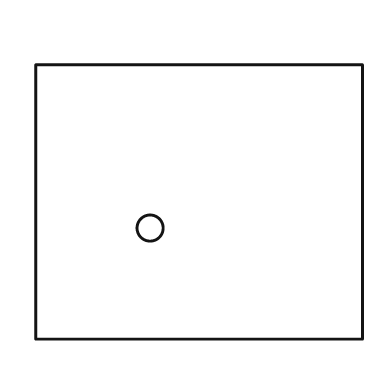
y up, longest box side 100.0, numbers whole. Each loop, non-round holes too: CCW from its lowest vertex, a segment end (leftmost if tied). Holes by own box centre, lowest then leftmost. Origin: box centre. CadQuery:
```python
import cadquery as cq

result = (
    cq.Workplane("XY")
    .moveTo(-50.0, -42.0)
    .lineTo(50.0, -42.0)
    .lineTo(50.0, 42.0)
    .lineTo(-50.0, 42.0)
    .close()
    .moveTo(-15.0, -8.0)
    .circle(4.0)
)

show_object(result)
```